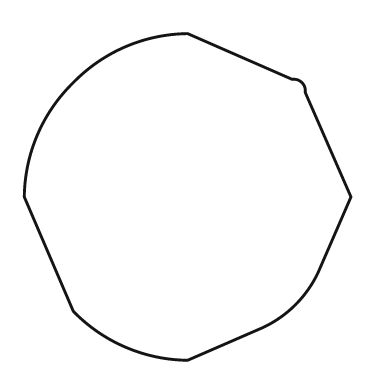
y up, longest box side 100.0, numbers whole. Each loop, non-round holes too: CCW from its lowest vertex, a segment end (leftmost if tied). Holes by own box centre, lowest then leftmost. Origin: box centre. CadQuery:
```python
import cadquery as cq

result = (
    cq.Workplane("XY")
    .moveTo(0.0, -50.0)
    .lineTo(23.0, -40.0)
    .threePointArc((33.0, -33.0), (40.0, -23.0))
    .lineTo(50.0, 0.0)
    .lineTo(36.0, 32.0)
    .threePointArc((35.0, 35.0), (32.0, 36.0))
    .lineTo(0.0, 50.0)
    .threePointArc((-19.0, 46.0), (-35.0, 35.0))
    .threePointArc((-46.0, 19.0), (-50.0, 0.0))
    .lineTo(-35.0, -35.0)
    .threePointArc((-19.0, -46.0), (0.0, -50.0))
    .close()
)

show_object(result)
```